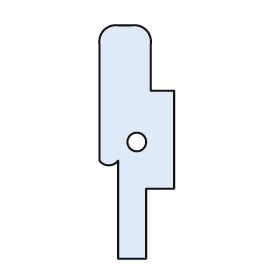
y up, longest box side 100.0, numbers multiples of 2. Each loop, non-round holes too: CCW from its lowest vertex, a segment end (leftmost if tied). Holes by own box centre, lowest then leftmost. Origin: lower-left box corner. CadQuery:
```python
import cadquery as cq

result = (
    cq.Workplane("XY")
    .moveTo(8.0, 0.0)
    .lineTo(20.0, 0.0)
    .lineTo(20.0, 30.0)
    .lineTo(32.0, 30.0)
    .lineTo(32.0, 72.0)
    .lineTo(22.0, 72.0)
    .lineTo(22.0, 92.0)
    .threePointArc((20.0, 98.0), (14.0, 100.0))
    .lineTo(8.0, 100.0)
    .threePointArc((2.0, 98.0), (0.0, 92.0))
    .lineTo(0.0, 42.0)
    .threePointArc((4.0, 40.0), (8.0, 42.0))
    .close()
    .moveTo(16.0, 50.0)
    .circle(4.0)
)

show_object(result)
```